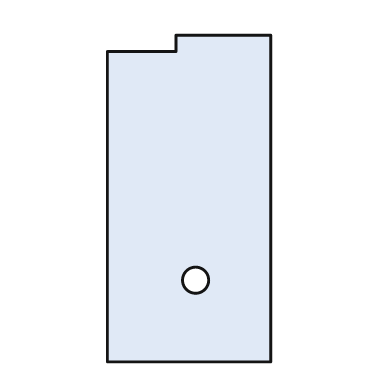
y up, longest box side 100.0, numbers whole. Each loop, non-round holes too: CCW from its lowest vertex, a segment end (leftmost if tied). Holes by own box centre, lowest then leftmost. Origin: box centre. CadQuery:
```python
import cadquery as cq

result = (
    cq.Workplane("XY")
    .moveTo(-25.0, -50.0)
    .lineTo(25.0, -50.0)
    .lineTo(25.0, 50.0)
    .lineTo(-4.0, 50.0)
    .lineTo(-4.0, 45.0)
    .lineTo(-25.0, 45.0)
    .close()
    .moveTo(2.0, -25.0)
    .circle(4.0)
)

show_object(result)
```